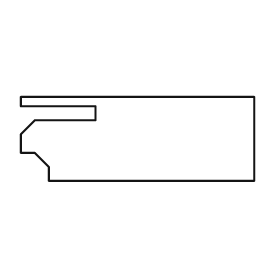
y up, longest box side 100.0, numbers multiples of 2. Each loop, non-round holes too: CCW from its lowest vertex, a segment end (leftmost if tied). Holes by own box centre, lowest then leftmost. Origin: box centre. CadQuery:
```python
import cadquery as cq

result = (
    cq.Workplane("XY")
    .moveTo(-38.0, -18.0)
    .lineTo(50.0, -18.0)
    .lineTo(50.0, 18.0)
    .lineTo(-50.0, 18.0)
    .lineTo(-50.0, 14.0)
    .lineTo(-18.0, 14.0)
    .lineTo(-18.0, 8.0)
    .lineTo(-44.0, 8.0)
    .lineTo(-50.0, 2.0)
    .lineTo(-50.0, -6.0)
    .lineTo(-44.0, -6.0)
    .lineTo(-38.0, -12.0)
    .close()
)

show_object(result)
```